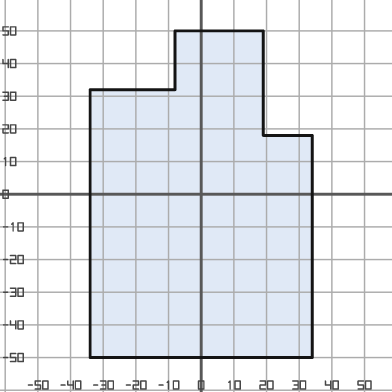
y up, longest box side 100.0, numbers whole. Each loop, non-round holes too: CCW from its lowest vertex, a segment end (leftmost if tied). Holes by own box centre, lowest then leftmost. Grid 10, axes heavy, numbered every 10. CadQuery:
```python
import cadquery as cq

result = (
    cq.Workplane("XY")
    .moveTo(-34.0, -50.0)
    .lineTo(34.0, -50.0)
    .lineTo(34.0, 18.0)
    .lineTo(19.0, 18.0)
    .lineTo(19.0, 50.0)
    .lineTo(-8.0, 50.0)
    .lineTo(-8.0, 32.0)
    .lineTo(-34.0, 32.0)
    .close()
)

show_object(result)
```